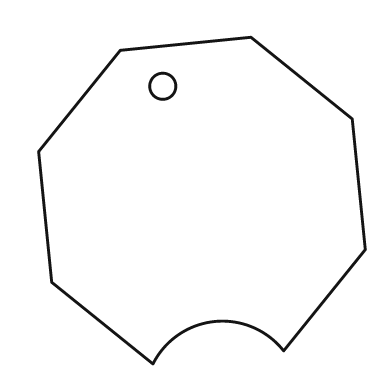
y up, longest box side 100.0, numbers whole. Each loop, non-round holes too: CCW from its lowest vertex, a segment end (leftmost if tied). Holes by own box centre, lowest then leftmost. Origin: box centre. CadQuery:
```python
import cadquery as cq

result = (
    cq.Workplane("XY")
    .moveTo(-15.0, -50.0)
    .threePointArc((4.0, -37.0), (25.0, -46.0))
    .lineTo(50.0, -15.0)
    .lineTo(46.0, 25.0)
    .lineTo(15.0, 50.0)
    .lineTo(-25.0, 46.0)
    .lineTo(-50.0, 15.0)
    .lineTo(-46.0, -25.0)
    .close()
    .moveTo(-12.0, 35.0)
    .circle(4.0)
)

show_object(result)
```